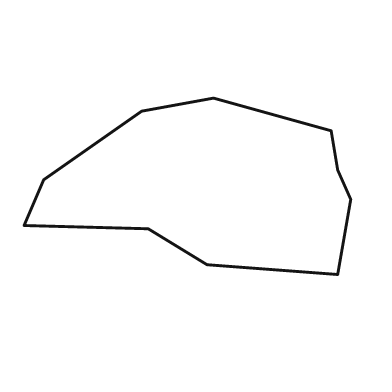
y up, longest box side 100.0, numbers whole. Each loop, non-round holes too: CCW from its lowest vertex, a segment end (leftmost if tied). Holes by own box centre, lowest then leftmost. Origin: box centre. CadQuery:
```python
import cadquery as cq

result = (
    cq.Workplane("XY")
    .moveTo(46.0, -27.0)
    .lineTo(50.0, -4.0)
    .lineTo(46.0, 5.0)
    .lineTo(44.0, 17.0)
    .lineTo(8.0, 27.0)
    .lineTo(-14.0, 23.0)
    .lineTo(-44.0, 2.0)
    .lineTo(-50.0, -12.0)
    .lineTo(-12.0, -13.0)
    .lineTo(6.0, -24.0)
    .close()
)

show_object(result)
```